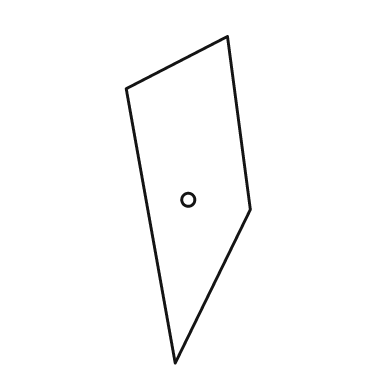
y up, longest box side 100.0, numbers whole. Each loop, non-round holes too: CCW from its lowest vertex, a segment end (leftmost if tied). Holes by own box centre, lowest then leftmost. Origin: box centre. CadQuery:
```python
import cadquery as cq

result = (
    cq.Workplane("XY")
    .moveTo(-4.0, -50.0)
    .lineTo(19.0, -3.0)
    .lineTo(12.0, 50.0)
    .lineTo(-19.0, 34.0)
    .close()
    .moveTo(0.0, 0.0)
    .circle(2.0)
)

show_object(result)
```